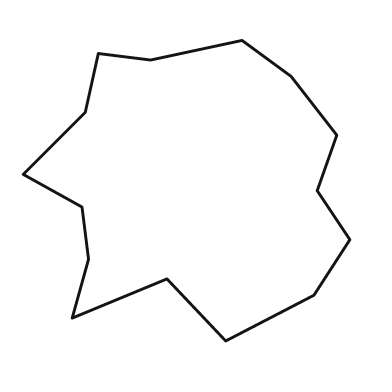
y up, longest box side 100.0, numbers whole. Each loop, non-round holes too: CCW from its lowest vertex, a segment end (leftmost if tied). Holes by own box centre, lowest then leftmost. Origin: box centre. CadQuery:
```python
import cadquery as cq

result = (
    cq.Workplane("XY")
    .moveTo(12.0, -46.0)
    .lineTo(39.0, -32.0)
    .lineTo(50.0, -15.0)
    .lineTo(40.0, 0.0)
    .lineTo(46.0, 17.0)
    .lineTo(32.0, 35.0)
    .lineTo(17.0, 46.0)
    .lineTo(-11.0, 40.0)
    .lineTo(-27.0, 42.0)
    .lineTo(-31.0, 24.0)
    .lineTo(-50.0, 5.0)
    .lineTo(-32.0, -5.0)
    .lineTo(-30.0, -21.0)
    .lineTo(-35.0, -39.0)
    .lineTo(-6.0, -27.0)
    .close()
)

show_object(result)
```